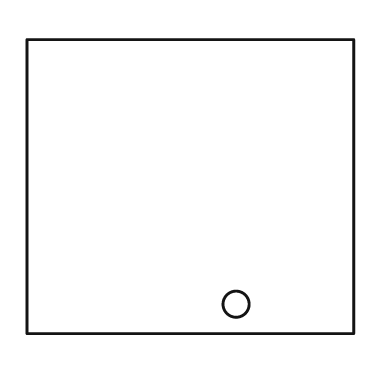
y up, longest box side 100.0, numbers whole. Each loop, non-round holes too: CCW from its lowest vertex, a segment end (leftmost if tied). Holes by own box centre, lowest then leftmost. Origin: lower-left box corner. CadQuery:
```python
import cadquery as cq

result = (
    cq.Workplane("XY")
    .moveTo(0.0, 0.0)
    .lineTo(100.0, 0.0)
    .lineTo(100.0, 90.0)
    .lineTo(0.0, 90.0)
    .close()
    .moveTo(64.0, 9.0)
    .circle(4.0)
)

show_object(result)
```